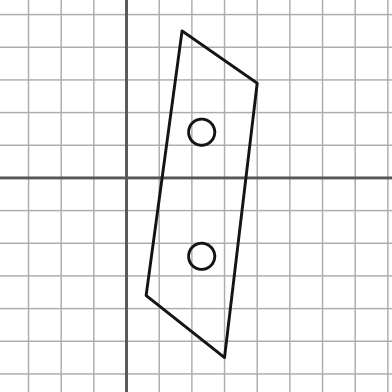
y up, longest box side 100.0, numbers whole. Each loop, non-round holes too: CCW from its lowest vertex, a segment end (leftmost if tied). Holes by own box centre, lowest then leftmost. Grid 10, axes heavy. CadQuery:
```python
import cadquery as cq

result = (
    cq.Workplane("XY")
    .moveTo(30.0, -55.0)
    .lineTo(40.0, 29.0)
    .lineTo(17.0, 45.0)
    .lineTo(6.0, -36.0)
    .close()
    .moveTo(23.0, -24.0)
    .circle(4.0)
    .moveTo(23.0, 14.0)
    .circle(4.0)
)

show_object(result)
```